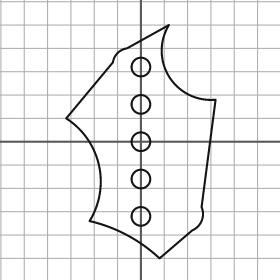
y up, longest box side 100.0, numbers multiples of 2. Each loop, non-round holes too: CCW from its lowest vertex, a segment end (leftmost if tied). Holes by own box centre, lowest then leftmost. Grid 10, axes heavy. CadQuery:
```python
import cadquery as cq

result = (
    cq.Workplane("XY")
    .moveTo(8.0, -50.0)
    .lineTo(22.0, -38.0)
    .threePointArc((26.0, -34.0), (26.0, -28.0))
    .lineTo(32.0, 18.0)
    .threePointArc((12.0, 28.0), (12.0, 50.0))
    .lineTo(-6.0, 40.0)
    .threePointArc((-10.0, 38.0), (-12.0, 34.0))
    .lineTo(-32.0, 10.0)
    .threePointArc((-18.0, -10.0), (-22.0, -34.0))
    .threePointArc((-6.0, -40.0), (8.0, -50.0))
    .close()
    .moveTo(0.0, -32.0)
    .circle(4.0)
    .moveTo(0.0, -16.0)
    .circle(4.0)
    .moveTo(0.0, 0.0)
    .circle(4.0)
    .moveTo(0.0, 16.0)
    .circle(4.0)
    .moveTo(0.0, 32.0)
    .circle(4.0)
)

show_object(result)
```